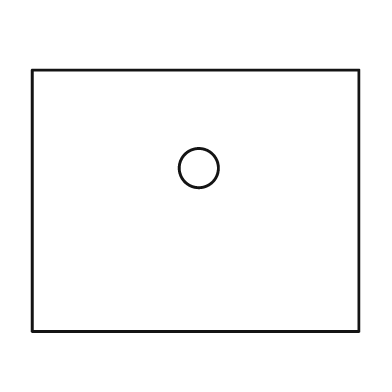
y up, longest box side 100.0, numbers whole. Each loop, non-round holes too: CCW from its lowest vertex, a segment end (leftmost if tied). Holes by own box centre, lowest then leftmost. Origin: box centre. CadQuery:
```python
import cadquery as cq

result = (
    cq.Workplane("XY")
    .moveTo(-50.0, -40.0)
    .lineTo(50.0, -40.0)
    .lineTo(50.0, 40.0)
    .lineTo(-50.0, 40.0)
    .close()
    .moveTo(1.0, 10.0)
    .circle(6.0)
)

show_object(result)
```